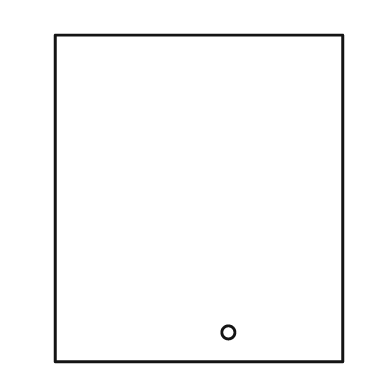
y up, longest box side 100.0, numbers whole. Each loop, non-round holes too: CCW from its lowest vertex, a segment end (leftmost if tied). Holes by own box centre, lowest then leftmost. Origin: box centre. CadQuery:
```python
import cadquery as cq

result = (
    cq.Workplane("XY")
    .moveTo(-44.0, -50.0)
    .lineTo(44.0, -50.0)
    .lineTo(44.0, 50.0)
    .lineTo(-44.0, 50.0)
    .close()
    .moveTo(9.0, -41.0)
    .circle(2.0)
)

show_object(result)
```